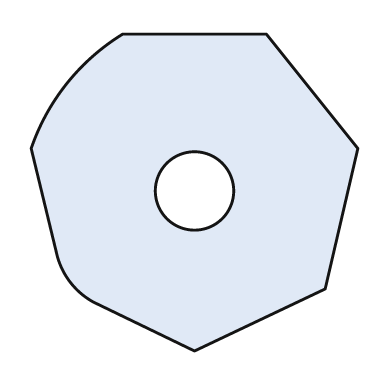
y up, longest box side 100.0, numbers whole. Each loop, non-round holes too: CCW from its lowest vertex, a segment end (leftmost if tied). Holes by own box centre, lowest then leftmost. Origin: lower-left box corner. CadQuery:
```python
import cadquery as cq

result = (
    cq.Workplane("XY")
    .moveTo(50.0, 0.0)
    .lineTo(90.0, 19.0)
    .lineTo(100.0, 62.0)
    .lineTo(72.0, 97.0)
    .lineTo(28.0, 97.0)
    .threePointArc((11.0, 82.0), (0.0, 62.0))
    .lineTo(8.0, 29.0)
    .threePointArc((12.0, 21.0), (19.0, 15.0))
    .close()
    .moveTo(50.0, 49.0)
    .circle(12.0)
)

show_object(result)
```